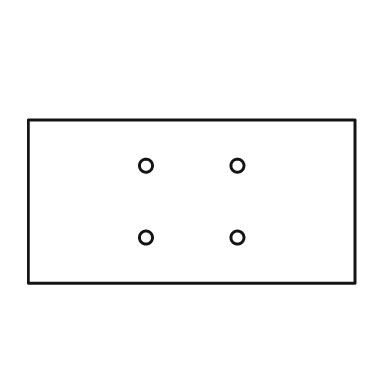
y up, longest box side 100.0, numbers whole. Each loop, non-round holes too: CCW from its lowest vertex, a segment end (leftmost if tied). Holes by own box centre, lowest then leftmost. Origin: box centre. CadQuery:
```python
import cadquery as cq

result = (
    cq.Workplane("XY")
    .moveTo(-50.0, -25.0)
    .lineTo(50.0, -25.0)
    .lineTo(50.0, 25.0)
    .lineTo(-50.0, 25.0)
    .close()
    .moveTo(-14.0, -11.0)
    .circle(2.0)
    .moveTo(14.0, -11.0)
    .circle(2.0)
    .moveTo(-14.0, 11.0)
    .circle(2.0)
    .moveTo(14.0, 11.0)
    .circle(2.0)
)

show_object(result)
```